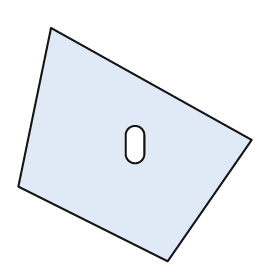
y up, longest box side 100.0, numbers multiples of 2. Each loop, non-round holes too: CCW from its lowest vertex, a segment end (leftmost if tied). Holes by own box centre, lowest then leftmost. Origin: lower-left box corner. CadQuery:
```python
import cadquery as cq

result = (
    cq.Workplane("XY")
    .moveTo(64.0, 0.0)
    .lineTo(100.0, 52.0)
    .lineTo(14.0, 100.0)
    .lineTo(0.0, 32.0)
    .close()
    .moveTo(46.0, 46.0)
    .threePointArc((50.0, 42.0), (54.0, 46.0))
    .lineTo(54.0, 54.0)
    .threePointArc((50.0, 58.0), (46.0, 54.0))
    .close()
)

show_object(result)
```